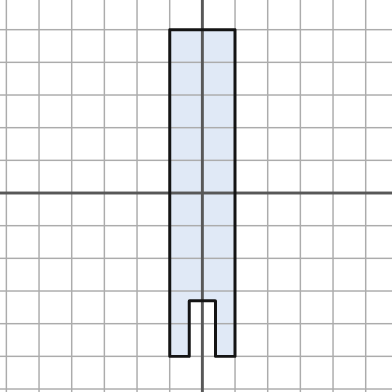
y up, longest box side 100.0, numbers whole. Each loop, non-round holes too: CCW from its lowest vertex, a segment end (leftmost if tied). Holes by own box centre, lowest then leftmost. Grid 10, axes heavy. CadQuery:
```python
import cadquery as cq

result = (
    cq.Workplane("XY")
    .moveTo(-10.0, -50.0)
    .lineTo(-4.0, -50.0)
    .lineTo(-4.0, -33.0)
    .lineTo(4.0, -33.0)
    .lineTo(4.0, -50.0)
    .lineTo(10.0, -50.0)
    .lineTo(10.0, 50.0)
    .lineTo(-10.0, 50.0)
    .close()
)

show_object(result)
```